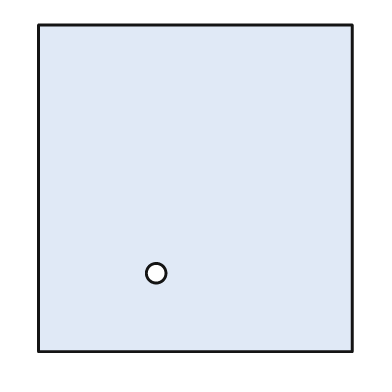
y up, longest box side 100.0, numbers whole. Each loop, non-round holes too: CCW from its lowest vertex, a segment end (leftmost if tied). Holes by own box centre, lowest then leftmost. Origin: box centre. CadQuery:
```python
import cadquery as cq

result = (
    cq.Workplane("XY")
    .moveTo(-48.0, -50.0)
    .lineTo(48.0, -50.0)
    .lineTo(48.0, 50.0)
    .lineTo(-48.0, 50.0)
    .close()
    .moveTo(-12.0, -26.0)
    .circle(3.0)
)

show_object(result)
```